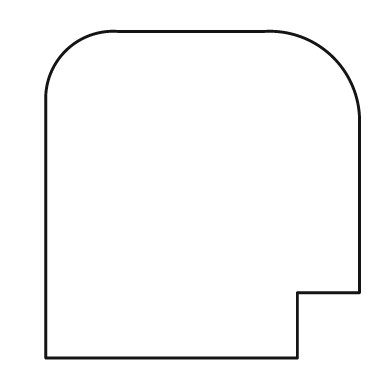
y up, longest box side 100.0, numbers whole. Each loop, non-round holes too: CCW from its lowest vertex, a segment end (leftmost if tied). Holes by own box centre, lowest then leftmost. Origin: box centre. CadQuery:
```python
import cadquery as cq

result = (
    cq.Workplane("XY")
    .moveTo(-48.0, -50.0)
    .lineTo(29.0, -50.0)
    .lineTo(29.0, -30.0)
    .lineTo(48.0, -30.0)
    .lineTo(48.0, 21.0)
    .threePointArc((40.0, 42.0), (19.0, 50.0))
    .lineTo(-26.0, 50.0)
    .threePointArc((-42.0, 44.0), (-48.0, 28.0))
    .close()
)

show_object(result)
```